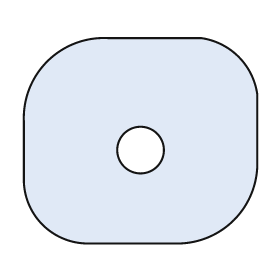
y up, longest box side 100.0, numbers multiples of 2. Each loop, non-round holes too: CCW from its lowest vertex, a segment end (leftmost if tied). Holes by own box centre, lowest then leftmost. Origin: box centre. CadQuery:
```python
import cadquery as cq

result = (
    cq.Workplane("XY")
    .moveTo(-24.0, -44.0)
    .lineTo(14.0, -44.0)
    .threePointArc((40.0, -34.0), (50.0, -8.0))
    .lineTo(50.0, 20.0)
    .threePointArc((42.0, 36.0), (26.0, 44.0))
    .lineTo(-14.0, 44.0)
    .threePointArc((-40.0, 34.0), (-50.0, 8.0))
    .lineTo(-50.0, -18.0)
    .threePointArc((-42.0, -36.0), (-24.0, -44.0))
    .close()
    .moveTo(0.0, -4.0)
    .circle(10.0)
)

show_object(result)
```